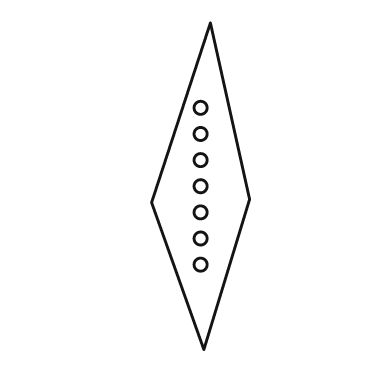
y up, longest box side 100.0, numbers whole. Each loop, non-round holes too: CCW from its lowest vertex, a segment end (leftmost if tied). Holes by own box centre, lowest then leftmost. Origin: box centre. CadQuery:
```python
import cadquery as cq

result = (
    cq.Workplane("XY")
    .moveTo(1.0, -50.0)
    .lineTo(15.0, -4.0)
    .lineTo(3.0, 50.0)
    .lineTo(-15.0, -5.0)
    .close()
    .moveTo(0.0, -24.0)
    .circle(2.0)
    .moveTo(0.0, -16.0)
    .circle(2.0)
    .moveTo(0.0, -8.0)
    .circle(2.0)
    .moveTo(0.0, 0.0)
    .circle(2.0)
    .moveTo(0.0, 8.0)
    .circle(2.0)
    .moveTo(0.0, 16.0)
    .circle(2.0)
    .moveTo(0.0, 24.0)
    .circle(2.0)
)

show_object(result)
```